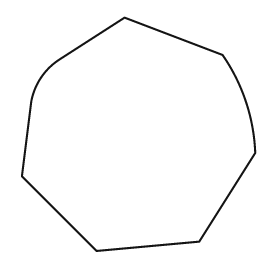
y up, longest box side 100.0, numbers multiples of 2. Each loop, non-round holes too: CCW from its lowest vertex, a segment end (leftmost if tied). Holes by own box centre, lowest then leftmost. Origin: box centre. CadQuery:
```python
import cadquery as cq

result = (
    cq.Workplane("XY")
    .moveTo(-18.0, -50.0)
    .lineTo(26.0, -46.0)
    .lineTo(50.0, -8.0)
    .threePointArc((46.0, 14.0), (36.0, 34.0))
    .lineTo(-6.0, 50.0)
    .lineTo(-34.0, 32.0)
    .threePointArc((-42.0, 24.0), (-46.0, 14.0))
    .lineTo(-50.0, -18.0)
    .close()
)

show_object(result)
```